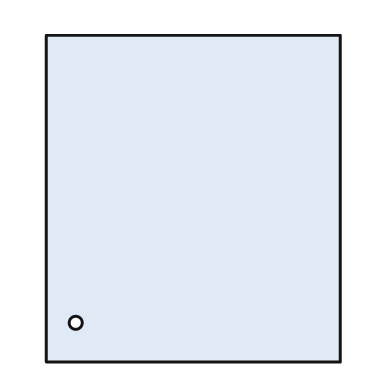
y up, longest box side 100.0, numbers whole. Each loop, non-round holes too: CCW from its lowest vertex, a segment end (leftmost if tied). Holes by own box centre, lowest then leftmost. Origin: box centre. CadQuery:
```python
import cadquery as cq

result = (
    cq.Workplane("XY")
    .moveTo(-45.0, -50.0)
    .lineTo(45.0, -50.0)
    .lineTo(45.0, 50.0)
    .lineTo(-45.0, 50.0)
    .close()
    .moveTo(-36.0, -38.0)
    .circle(2.0)
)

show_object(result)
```